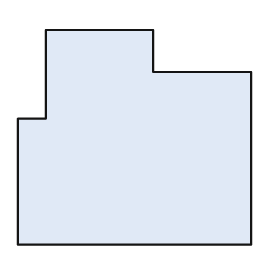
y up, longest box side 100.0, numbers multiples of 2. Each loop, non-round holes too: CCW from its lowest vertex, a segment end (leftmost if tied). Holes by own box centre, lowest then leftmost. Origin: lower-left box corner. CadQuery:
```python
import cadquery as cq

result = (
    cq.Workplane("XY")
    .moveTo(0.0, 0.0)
    .lineTo(100.0, 0.0)
    .lineTo(100.0, 74.0)
    .lineTo(58.0, 74.0)
    .lineTo(58.0, 92.0)
    .lineTo(12.0, 92.0)
    .lineTo(12.0, 54.0)
    .lineTo(0.0, 54.0)
    .close()
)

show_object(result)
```